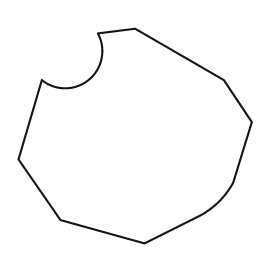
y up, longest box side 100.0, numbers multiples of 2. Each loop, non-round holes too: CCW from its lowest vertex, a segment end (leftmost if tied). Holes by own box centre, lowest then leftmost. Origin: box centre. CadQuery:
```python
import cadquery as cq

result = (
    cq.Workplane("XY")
    .moveTo(4.0, -46.0)
    .lineTo(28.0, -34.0)
    .threePointArc((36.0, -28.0), (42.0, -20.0))
    .lineTo(50.0, 6.0)
    .lineTo(38.0, 24.0)
    .lineTo(0.0, 46.0)
    .lineTo(-16.0, 44.0)
    .threePointArc((-20.0, 24.0), (-40.0, 24.0))
    .lineTo(-50.0, -10.0)
    .lineTo(-32.0, -36.0)
    .close()
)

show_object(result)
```